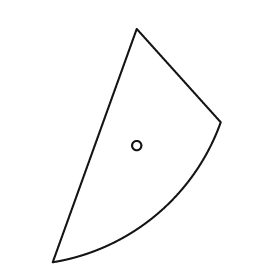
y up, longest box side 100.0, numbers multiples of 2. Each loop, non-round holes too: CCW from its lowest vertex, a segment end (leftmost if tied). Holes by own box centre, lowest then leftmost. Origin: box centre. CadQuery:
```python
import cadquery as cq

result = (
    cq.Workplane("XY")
    .moveTo(-36.0, -50.0)
    .threePointArc((8.0, -30.0), (36.0, 10.0))
    .lineTo(0.0, 50.0)
    .close()
    .moveTo(0.0, 0.0)
    .circle(2.0)
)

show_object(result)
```